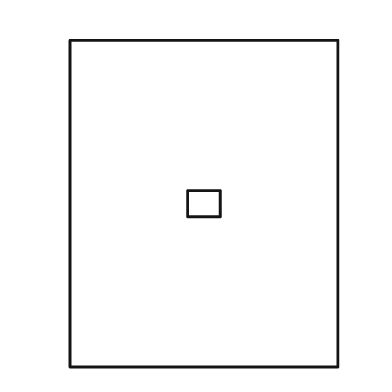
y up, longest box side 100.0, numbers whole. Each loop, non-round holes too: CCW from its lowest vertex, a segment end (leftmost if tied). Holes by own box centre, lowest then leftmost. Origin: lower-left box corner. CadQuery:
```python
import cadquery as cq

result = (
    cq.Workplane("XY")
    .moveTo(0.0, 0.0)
    .lineTo(82.0, 0.0)
    .lineTo(82.0, 100.0)
    .lineTo(0.0, 100.0)
    .close()
    .moveTo(36.0, 46.0)
    .lineTo(46.0, 46.0)
    .lineTo(46.0, 54.0)
    .lineTo(36.0, 54.0)
    .close()
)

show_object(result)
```